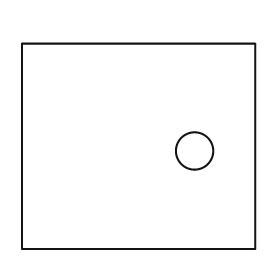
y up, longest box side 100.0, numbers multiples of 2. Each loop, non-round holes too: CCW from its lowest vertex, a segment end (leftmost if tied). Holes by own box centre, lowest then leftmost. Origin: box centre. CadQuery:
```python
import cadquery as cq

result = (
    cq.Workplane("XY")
    .moveTo(-50.0, -44.0)
    .lineTo(50.0, -44.0)
    .lineTo(50.0, 44.0)
    .lineTo(-50.0, 44.0)
    .close()
    .moveTo(24.0, -2.0)
    .circle(8.0)
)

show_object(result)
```